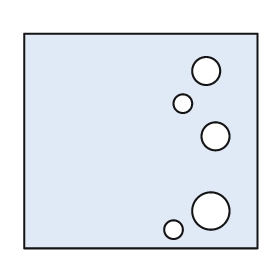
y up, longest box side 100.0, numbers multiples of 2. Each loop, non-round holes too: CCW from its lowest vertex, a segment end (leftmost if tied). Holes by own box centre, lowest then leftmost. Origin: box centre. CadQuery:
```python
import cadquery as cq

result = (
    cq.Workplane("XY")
    .moveTo(-50.0, -46.0)
    .lineTo(50.0, -46.0)
    .lineTo(50.0, 46.0)
    .lineTo(-50.0, 46.0)
    .close()
    .moveTo(14.0, -38.0)
    .circle(4.0)
    .moveTo(30.0, -30.0)
    .circle(8.0)
    .moveTo(32.0, 2.0)
    .circle(6.0)
    .moveTo(18.0, 16.0)
    .circle(4.0)
    .moveTo(28.0, 30.0)
    .circle(6.0)
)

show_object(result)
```